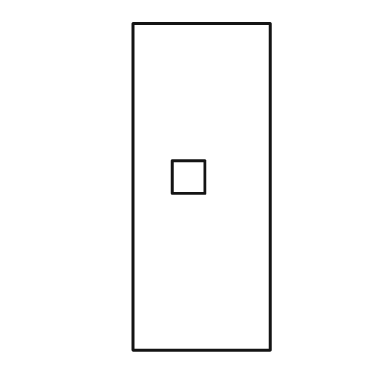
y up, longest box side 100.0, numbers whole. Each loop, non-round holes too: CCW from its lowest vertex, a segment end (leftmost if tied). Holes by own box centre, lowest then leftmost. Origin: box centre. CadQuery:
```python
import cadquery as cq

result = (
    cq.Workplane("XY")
    .moveTo(-21.0, -50.0)
    .lineTo(21.0, -50.0)
    .lineTo(21.0, 50.0)
    .lineTo(-21.0, 50.0)
    .close()
    .moveTo(-9.0, -2.0)
    .lineTo(1.0, -2.0)
    .lineTo(1.0, 8.0)
    .lineTo(-9.0, 8.0)
    .close()
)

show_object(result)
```